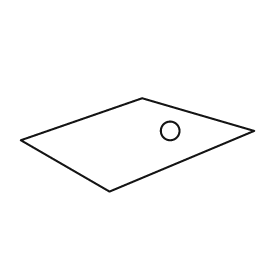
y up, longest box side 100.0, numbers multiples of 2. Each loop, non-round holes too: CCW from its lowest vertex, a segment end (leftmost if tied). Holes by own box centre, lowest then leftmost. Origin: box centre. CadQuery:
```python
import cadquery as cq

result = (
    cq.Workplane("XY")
    .moveTo(-12.0, -20.0)
    .lineTo(50.0, 6.0)
    .lineTo(2.0, 20.0)
    .lineTo(-50.0, 2.0)
    .close()
    .moveTo(14.0, 6.0)
    .circle(4.0)
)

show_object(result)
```